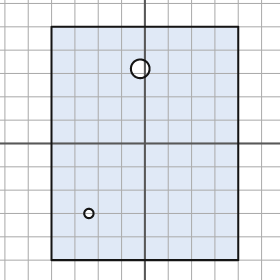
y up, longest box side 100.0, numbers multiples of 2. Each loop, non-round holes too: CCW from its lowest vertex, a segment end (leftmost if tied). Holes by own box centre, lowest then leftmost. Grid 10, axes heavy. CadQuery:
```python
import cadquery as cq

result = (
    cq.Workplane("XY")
    .moveTo(-40.0, -50.0)
    .lineTo(40.0, -50.0)
    .lineTo(40.0, 50.0)
    .lineTo(-40.0, 50.0)
    .close()
    .moveTo(-24.0, -30.0)
    .circle(2.0)
    .moveTo(-2.0, 32.0)
    .circle(4.0)
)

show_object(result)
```